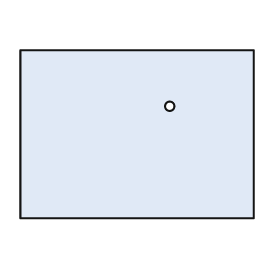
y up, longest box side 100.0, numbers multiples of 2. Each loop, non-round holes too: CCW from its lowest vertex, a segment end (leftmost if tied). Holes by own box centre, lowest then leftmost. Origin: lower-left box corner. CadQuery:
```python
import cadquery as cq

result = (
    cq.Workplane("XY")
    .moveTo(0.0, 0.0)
    .lineTo(100.0, 0.0)
    .lineTo(100.0, 72.0)
    .lineTo(0.0, 72.0)
    .close()
    .moveTo(64.0, 48.0)
    .circle(2.0)
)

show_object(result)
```